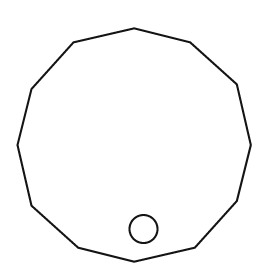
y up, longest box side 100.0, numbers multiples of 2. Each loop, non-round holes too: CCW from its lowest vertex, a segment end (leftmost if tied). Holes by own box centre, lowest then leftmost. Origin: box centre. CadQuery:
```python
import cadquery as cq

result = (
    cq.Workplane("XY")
    .moveTo(0.0, -50.0)
    .lineTo(26.0, -44.0)
    .lineTo(44.0, -24.0)
    .lineTo(50.0, 0.0)
    .lineTo(44.0, 26.0)
    .lineTo(24.0, 44.0)
    .lineTo(0.0, 50.0)
    .lineTo(-26.0, 44.0)
    .lineTo(-44.0, 24.0)
    .lineTo(-50.0, 0.0)
    .lineTo(-44.0, -26.0)
    .lineTo(-24.0, -44.0)
    .close()
    .moveTo(4.0, -36.0)
    .circle(6.0)
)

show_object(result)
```